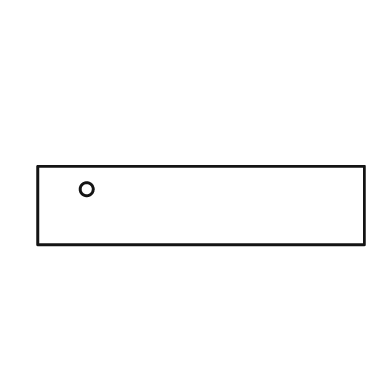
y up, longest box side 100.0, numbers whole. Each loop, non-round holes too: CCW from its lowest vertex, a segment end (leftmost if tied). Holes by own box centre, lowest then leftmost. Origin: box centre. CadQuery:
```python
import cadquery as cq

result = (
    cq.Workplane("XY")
    .moveTo(-50.0, -12.0)
    .lineTo(50.0, -12.0)
    .lineTo(50.0, 12.0)
    .lineTo(-50.0, 12.0)
    .close()
    .moveTo(-35.0, 5.0)
    .circle(2.0)
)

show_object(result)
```